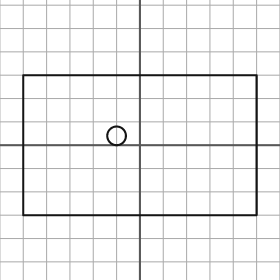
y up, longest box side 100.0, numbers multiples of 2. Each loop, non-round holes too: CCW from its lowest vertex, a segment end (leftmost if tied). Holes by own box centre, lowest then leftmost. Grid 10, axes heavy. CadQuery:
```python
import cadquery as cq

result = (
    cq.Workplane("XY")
    .moveTo(-50.0, -30.0)
    .lineTo(50.0, -30.0)
    .lineTo(50.0, 30.0)
    .lineTo(-50.0, 30.0)
    .close()
    .moveTo(-10.0, 4.0)
    .circle(4.0)
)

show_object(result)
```